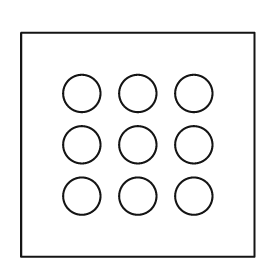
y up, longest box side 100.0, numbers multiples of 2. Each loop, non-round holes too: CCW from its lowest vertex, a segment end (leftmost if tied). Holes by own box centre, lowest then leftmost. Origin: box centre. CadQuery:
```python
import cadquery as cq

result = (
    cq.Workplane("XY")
    .moveTo(-50.0, -48.0)
    .lineTo(50.0, -48.0)
    .lineTo(50.0, 48.0)
    .lineTo(-50.0, 48.0)
    .close()
    .moveTo(-24.0, -22.0)
    .circle(8.0)
    .moveTo(0.0, -22.0)
    .circle(8.0)
    .moveTo(24.0, -22.0)
    .circle(8.0)
    .moveTo(-24.0, 0.0)
    .circle(8.0)
    .moveTo(0.0, 0.0)
    .circle(8.0)
    .moveTo(24.0, 0.0)
    .circle(8.0)
    .moveTo(-24.0, 22.0)
    .circle(8.0)
    .moveTo(0.0, 22.0)
    .circle(8.0)
    .moveTo(24.0, 22.0)
    .circle(8.0)
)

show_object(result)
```